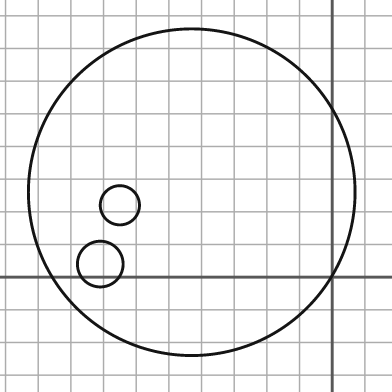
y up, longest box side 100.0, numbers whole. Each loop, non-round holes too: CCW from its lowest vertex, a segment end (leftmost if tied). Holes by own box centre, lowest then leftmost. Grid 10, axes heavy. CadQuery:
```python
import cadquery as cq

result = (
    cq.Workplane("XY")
    .moveTo(-43.0, 26.0)
    .circle(50.0)
    .moveTo(-71.0, 4.0)
    .circle(7.0)
    .moveTo(-65.0, 22.0)
    .circle(6.0)
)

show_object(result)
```